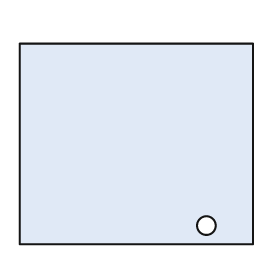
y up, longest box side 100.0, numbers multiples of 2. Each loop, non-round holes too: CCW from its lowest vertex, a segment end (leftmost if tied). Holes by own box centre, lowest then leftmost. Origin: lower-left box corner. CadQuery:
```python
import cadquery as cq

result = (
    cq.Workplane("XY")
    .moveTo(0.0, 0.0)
    .lineTo(100.0, 0.0)
    .lineTo(100.0, 86.0)
    .lineTo(0.0, 86.0)
    .close()
    .moveTo(80.0, 8.0)
    .circle(4.0)
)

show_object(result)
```